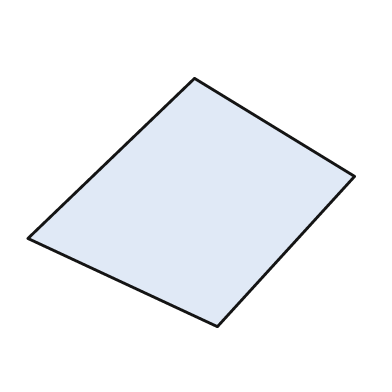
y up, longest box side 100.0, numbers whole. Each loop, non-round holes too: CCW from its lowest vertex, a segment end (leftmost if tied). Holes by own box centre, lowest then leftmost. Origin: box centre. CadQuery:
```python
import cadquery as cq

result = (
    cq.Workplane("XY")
    .moveTo(8.0, -38.0)
    .lineTo(50.0, 8.0)
    .lineTo(1.0, 38.0)
    .lineTo(-50.0, -11.0)
    .close()
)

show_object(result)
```